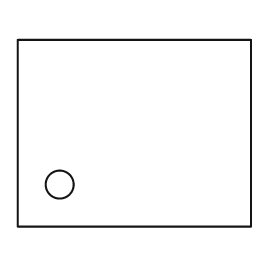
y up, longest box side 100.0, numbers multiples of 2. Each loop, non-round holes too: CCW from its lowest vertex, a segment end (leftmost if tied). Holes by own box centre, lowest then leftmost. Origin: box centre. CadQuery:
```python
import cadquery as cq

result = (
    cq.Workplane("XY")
    .moveTo(-50.0, -40.0)
    .lineTo(50.0, -40.0)
    .lineTo(50.0, 40.0)
    .lineTo(-50.0, 40.0)
    .close()
    .moveTo(-32.0, -22.0)
    .circle(6.0)
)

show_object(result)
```